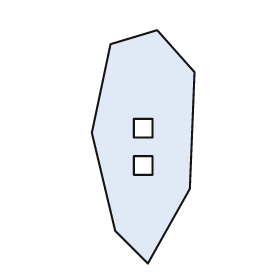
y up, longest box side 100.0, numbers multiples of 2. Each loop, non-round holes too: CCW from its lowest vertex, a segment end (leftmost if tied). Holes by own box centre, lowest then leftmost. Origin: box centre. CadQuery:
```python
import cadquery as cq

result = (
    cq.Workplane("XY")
    .moveTo(2.0, -50.0)
    .lineTo(20.0, -18.0)
    .lineTo(22.0, 32.0)
    .lineTo(6.0, 50.0)
    .lineTo(-14.0, 44.0)
    .lineTo(-22.0, 6.0)
    .lineTo(-12.0, -36.0)
    .close()
    .moveTo(-4.0, -12.0)
    .lineTo(4.0, -12.0)
    .lineTo(4.0, -4.0)
    .lineTo(-4.0, -4.0)
    .close()
    .moveTo(-4.0, 4.0)
    .lineTo(4.0, 4.0)
    .lineTo(4.0, 12.0)
    .lineTo(-4.0, 12.0)
    .close()
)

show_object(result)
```